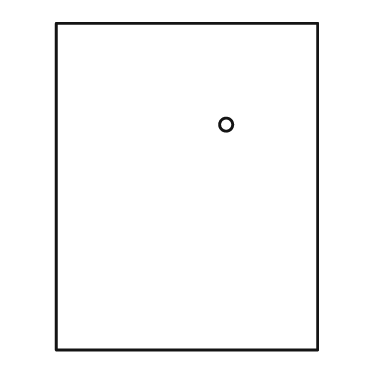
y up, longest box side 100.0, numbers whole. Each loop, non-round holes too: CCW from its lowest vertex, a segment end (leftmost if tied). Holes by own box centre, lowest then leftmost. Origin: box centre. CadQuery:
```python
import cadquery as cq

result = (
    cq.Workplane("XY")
    .moveTo(-40.0, -50.0)
    .lineTo(40.0, -50.0)
    .lineTo(40.0, 50.0)
    .lineTo(-40.0, 50.0)
    .close()
    .moveTo(12.0, 19.0)
    .circle(2.0)
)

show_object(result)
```